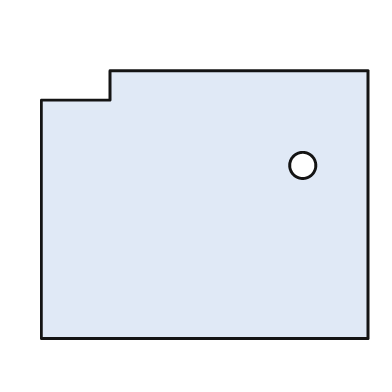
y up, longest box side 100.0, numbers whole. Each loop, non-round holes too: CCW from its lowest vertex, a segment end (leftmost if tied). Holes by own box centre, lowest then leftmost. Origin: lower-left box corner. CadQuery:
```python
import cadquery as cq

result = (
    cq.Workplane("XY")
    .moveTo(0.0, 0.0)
    .lineTo(100.0, 0.0)
    .lineTo(100.0, 82.0)
    .lineTo(21.0, 82.0)
    .lineTo(21.0, 73.0)
    .lineTo(0.0, 73.0)
    .close()
    .moveTo(80.0, 53.0)
    .circle(4.0)
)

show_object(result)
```